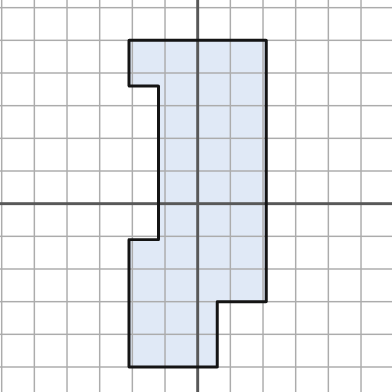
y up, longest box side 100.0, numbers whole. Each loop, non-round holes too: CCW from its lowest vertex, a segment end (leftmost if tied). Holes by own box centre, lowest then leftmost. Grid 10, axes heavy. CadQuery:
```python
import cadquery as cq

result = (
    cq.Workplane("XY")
    .moveTo(-21.0, -50.0)
    .lineTo(6.0, -50.0)
    .lineTo(6.0, -30.0)
    .lineTo(21.0, -30.0)
    .lineTo(21.0, 50.0)
    .lineTo(-21.0, 50.0)
    .lineTo(-21.0, 36.0)
    .lineTo(-12.0, 36.0)
    .lineTo(-12.0, -11.0)
    .lineTo(-21.0, -11.0)
    .close()
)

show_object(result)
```